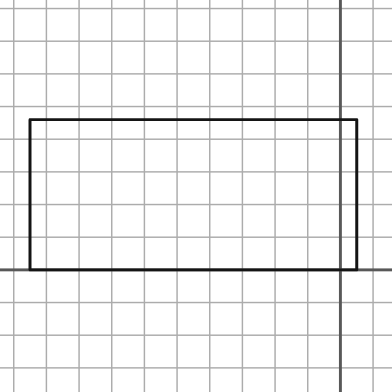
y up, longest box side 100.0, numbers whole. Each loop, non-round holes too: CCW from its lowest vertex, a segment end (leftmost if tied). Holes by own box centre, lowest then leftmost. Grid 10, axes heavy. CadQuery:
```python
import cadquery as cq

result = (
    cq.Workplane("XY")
    .moveTo(-95.0, 0.0)
    .lineTo(5.0, 0.0)
    .lineTo(5.0, 46.0)
    .lineTo(-95.0, 46.0)
    .close()
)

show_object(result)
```